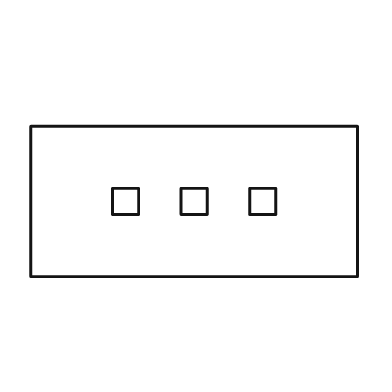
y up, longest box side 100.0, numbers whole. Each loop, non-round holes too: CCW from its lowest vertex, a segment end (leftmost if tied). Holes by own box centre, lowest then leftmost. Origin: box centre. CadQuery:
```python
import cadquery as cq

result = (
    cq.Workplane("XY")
    .moveTo(-50.0, -23.0)
    .lineTo(50.0, -23.0)
    .lineTo(50.0, 23.0)
    .lineTo(-50.0, 23.0)
    .close()
    .moveTo(-25.0, -4.0)
    .lineTo(-17.0, -4.0)
    .lineTo(-17.0, 4.0)
    .lineTo(-25.0, 4.0)
    .close()
    .moveTo(-4.0, -4.0)
    .lineTo(4.0, -4.0)
    .lineTo(4.0, 4.0)
    .lineTo(-4.0, 4.0)
    .close()
    .moveTo(17.0, -4.0)
    .lineTo(25.0, -4.0)
    .lineTo(25.0, 4.0)
    .lineTo(17.0, 4.0)
    .close()
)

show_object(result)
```